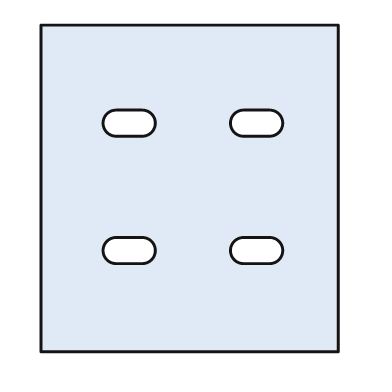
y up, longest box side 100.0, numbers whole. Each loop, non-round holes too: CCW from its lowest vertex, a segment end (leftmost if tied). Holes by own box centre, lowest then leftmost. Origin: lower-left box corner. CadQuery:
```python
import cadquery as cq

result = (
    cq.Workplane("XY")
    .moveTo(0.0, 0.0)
    .lineTo(91.0, 0.0)
    .lineTo(91.0, 100.0)
    .lineTo(0.0, 100.0)
    .close()
    .moveTo(23.0, 27.0)
    .lineTo(31.0, 27.0)
    .threePointArc((35.0, 31.0), (31.0, 35.0))
    .lineTo(23.0, 35.0)
    .threePointArc((19.0, 31.0), (23.0, 27.0))
    .close()
    .moveTo(62.0, 27.0)
    .lineTo(70.0, 27.0)
    .threePointArc((74.0, 31.0), (70.0, 35.0))
    .lineTo(62.0, 35.0)
    .threePointArc((58.0, 31.0), (62.0, 27.0))
    .close()
    .moveTo(23.0, 66.0)
    .lineTo(31.0, 66.0)
    .threePointArc((35.0, 70.0), (31.0, 74.0))
    .lineTo(23.0, 74.0)
    .threePointArc((19.0, 70.0), (23.0, 66.0))
    .close()
    .moveTo(62.0, 66.0)
    .lineTo(70.0, 66.0)
    .threePointArc((74.0, 70.0), (70.0, 74.0))
    .lineTo(62.0, 74.0)
    .threePointArc((58.0, 70.0), (62.0, 66.0))
    .close()
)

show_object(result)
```